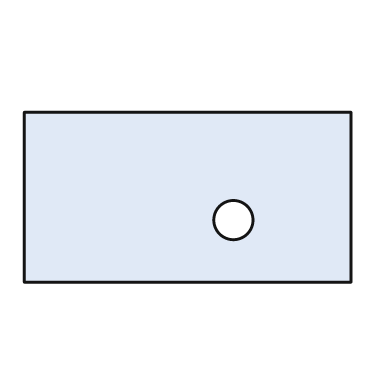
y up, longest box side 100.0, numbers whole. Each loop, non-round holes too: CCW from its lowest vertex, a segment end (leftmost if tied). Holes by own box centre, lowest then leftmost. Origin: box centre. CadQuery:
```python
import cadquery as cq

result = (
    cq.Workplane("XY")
    .moveTo(-50.0, -26.0)
    .lineTo(50.0, -26.0)
    .lineTo(50.0, 26.0)
    .lineTo(-50.0, 26.0)
    .close()
    .moveTo(14.0, -7.0)
    .circle(6.0)
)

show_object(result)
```